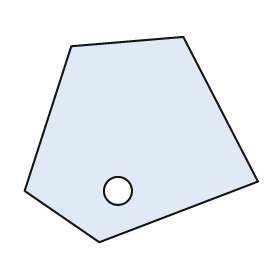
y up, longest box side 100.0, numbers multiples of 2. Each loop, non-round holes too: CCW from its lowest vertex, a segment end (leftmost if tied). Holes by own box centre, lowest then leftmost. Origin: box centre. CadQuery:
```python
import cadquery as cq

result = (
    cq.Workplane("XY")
    .moveTo(-18.0, -44.0)
    .lineTo(50.0, -18.0)
    .lineTo(18.0, 44.0)
    .lineTo(-30.0, 40.0)
    .lineTo(-50.0, -22.0)
    .close()
    .moveTo(-10.0, -22.0)
    .circle(6.0)
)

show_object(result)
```